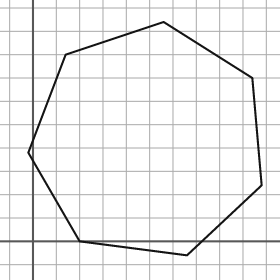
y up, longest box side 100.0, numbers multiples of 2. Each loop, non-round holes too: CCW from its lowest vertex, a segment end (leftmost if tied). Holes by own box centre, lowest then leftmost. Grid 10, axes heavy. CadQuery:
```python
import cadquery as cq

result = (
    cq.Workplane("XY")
    .moveTo(66.0, -6.0)
    .lineTo(98.0, 24.0)
    .lineTo(94.0, 70.0)
    .lineTo(56.0, 94.0)
    .lineTo(14.0, 80.0)
    .lineTo(-2.0, 38.0)
    .lineTo(20.0, 0.0)
    .close()
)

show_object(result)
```